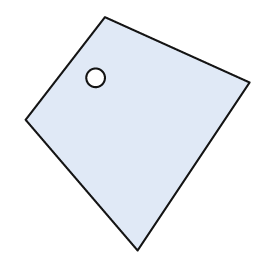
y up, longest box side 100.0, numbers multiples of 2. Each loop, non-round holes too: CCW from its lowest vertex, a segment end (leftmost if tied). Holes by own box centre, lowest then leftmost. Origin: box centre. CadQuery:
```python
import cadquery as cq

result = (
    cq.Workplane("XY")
    .moveTo(0.0, -50.0)
    .lineTo(48.0, 22.0)
    .lineTo(-14.0, 50.0)
    .lineTo(-48.0, 6.0)
    .close()
    .moveTo(-18.0, 24.0)
    .circle(4.0)
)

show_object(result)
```